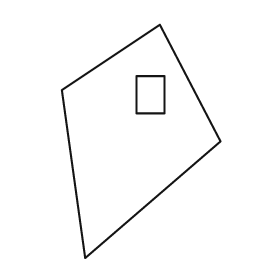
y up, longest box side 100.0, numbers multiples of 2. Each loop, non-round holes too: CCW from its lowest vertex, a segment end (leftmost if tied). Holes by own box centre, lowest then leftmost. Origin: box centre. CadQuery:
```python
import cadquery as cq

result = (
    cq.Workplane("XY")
    .moveTo(-24.0, -50.0)
    .lineTo(34.0, 0.0)
    .lineTo(8.0, 50.0)
    .lineTo(-34.0, 22.0)
    .close()
    .moveTo(-2.0, 12.0)
    .lineTo(10.0, 12.0)
    .lineTo(10.0, 28.0)
    .lineTo(-2.0, 28.0)
    .close()
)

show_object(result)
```